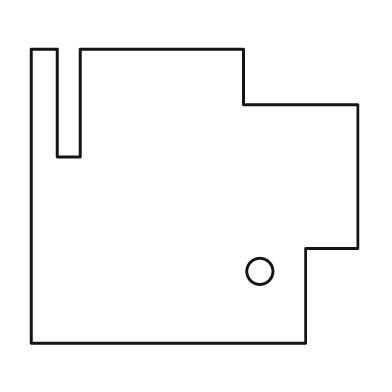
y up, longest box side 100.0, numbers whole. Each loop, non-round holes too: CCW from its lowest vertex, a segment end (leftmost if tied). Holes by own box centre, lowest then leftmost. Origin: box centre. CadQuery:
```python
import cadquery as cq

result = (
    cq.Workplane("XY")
    .moveTo(-50.0, -45.0)
    .lineTo(34.0, -45.0)
    .lineTo(34.0, -16.0)
    .lineTo(50.0, -16.0)
    .lineTo(50.0, 28.0)
    .lineTo(15.0, 28.0)
    .lineTo(15.0, 45.0)
    .lineTo(-35.0, 45.0)
    .lineTo(-35.0, 12.0)
    .lineTo(-42.0, 12.0)
    .lineTo(-42.0, 45.0)
    .lineTo(-50.0, 45.0)
    .close()
    .moveTo(20.0, -23.0)
    .circle(4.0)
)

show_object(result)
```